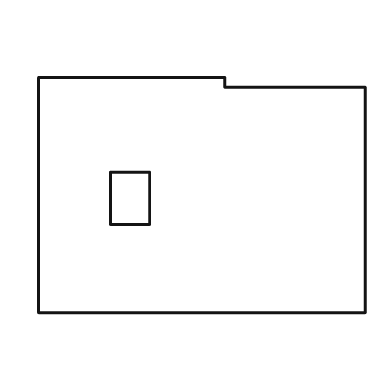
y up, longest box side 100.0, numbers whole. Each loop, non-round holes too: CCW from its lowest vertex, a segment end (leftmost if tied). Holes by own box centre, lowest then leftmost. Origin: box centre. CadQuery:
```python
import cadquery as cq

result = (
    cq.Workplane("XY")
    .moveTo(-50.0, -36.0)
    .lineTo(50.0, -36.0)
    .lineTo(50.0, 33.0)
    .lineTo(7.0, 33.0)
    .lineTo(7.0, 36.0)
    .lineTo(-50.0, 36.0)
    .close()
    .moveTo(-28.0, -9.0)
    .lineTo(-16.0, -9.0)
    .lineTo(-16.0, 7.0)
    .lineTo(-28.0, 7.0)
    .close()
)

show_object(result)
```